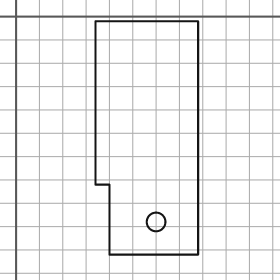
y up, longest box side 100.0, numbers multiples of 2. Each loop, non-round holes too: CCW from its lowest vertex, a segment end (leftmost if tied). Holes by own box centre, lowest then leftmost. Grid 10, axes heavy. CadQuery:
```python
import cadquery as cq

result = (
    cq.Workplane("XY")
    .moveTo(40.0, -102.0)
    .lineTo(78.0, -102.0)
    .lineTo(78.0, -2.0)
    .lineTo(34.0, -2.0)
    .lineTo(34.0, -72.0)
    .lineTo(40.0, -72.0)
    .close()
    .moveTo(60.0, -88.0)
    .circle(4.0)
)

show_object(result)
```